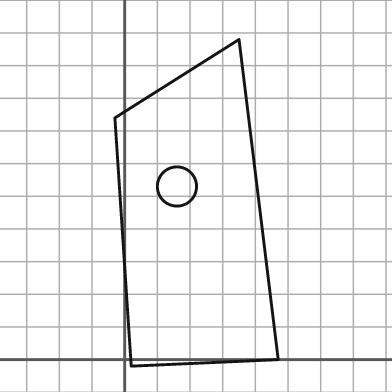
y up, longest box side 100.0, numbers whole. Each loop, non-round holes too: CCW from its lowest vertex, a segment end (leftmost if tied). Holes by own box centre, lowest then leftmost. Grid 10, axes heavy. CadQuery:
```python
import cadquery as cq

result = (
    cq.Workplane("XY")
    .moveTo(2.0, -2.0)
    .lineTo(47.0, 0.0)
    .lineTo(35.0, 98.0)
    .lineTo(-3.0, 74.0)
    .close()
    .moveTo(16.0, 53.0)
    .circle(6.0)
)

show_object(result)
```